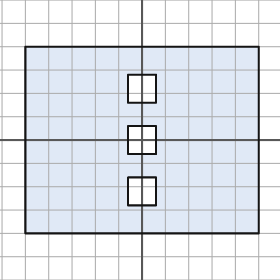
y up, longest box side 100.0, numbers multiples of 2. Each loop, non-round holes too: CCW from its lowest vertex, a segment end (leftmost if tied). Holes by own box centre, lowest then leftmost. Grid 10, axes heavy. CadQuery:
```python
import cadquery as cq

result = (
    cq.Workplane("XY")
    .moveTo(-50.0, -40.0)
    .lineTo(50.0, -40.0)
    .lineTo(50.0, 40.0)
    .lineTo(-50.0, 40.0)
    .close()
    .moveTo(-6.0, -28.0)
    .lineTo(6.0, -28.0)
    .lineTo(6.0, -16.0)
    .lineTo(-6.0, -16.0)
    .close()
    .moveTo(-6.0, -6.0)
    .lineTo(6.0, -6.0)
    .lineTo(6.0, 6.0)
    .lineTo(-6.0, 6.0)
    .close()
    .moveTo(-6.0, 16.0)
    .lineTo(6.0, 16.0)
    .lineTo(6.0, 28.0)
    .lineTo(-6.0, 28.0)
    .close()
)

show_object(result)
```